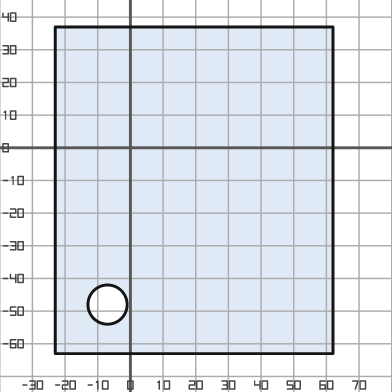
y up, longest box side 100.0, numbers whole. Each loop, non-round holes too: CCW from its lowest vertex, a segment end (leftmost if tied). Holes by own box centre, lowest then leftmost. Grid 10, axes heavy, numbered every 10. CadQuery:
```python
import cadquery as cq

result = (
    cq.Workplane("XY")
    .moveTo(-23.0, -63.0)
    .lineTo(62.0, -63.0)
    .lineTo(62.0, 37.0)
    .lineTo(-23.0, 37.0)
    .close()
    .moveTo(-7.0, -48.0)
    .circle(6.0)
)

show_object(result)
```